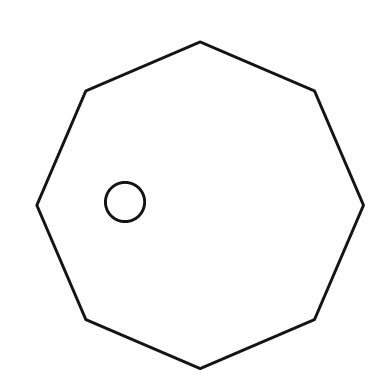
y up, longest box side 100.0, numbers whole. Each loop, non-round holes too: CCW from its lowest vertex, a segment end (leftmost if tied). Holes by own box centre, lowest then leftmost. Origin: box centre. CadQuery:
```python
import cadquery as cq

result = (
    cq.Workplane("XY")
    .moveTo(0.0, -50.0)
    .lineTo(35.0, -35.0)
    .lineTo(50.0, 0.0)
    .lineTo(35.0, 35.0)
    .lineTo(0.0, 50.0)
    .lineTo(-35.0, 35.0)
    .lineTo(-50.0, 0.0)
    .lineTo(-35.0, -35.0)
    .close()
    .moveTo(-23.0, 1.0)
    .circle(6.0)
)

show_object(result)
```